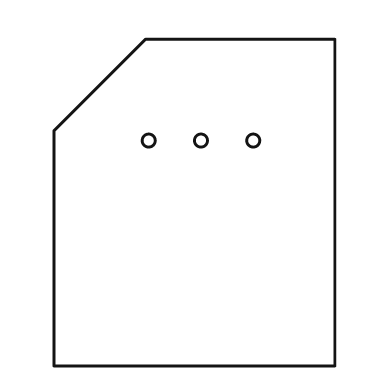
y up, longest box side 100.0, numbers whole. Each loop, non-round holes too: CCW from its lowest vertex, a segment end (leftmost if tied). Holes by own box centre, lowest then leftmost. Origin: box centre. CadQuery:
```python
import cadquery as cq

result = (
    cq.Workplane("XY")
    .moveTo(-43.0, -50.0)
    .lineTo(43.0, -50.0)
    .lineTo(43.0, 50.0)
    .lineTo(-15.0, 50.0)
    .lineTo(-43.0, 22.0)
    .close()
    .moveTo(-14.0, 19.0)
    .circle(2.0)
    .moveTo(2.0, 19.0)
    .circle(2.0)
    .moveTo(18.0, 19.0)
    .circle(2.0)
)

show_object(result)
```